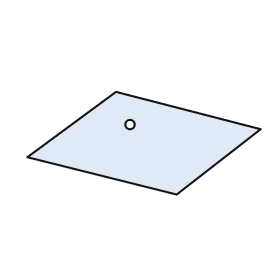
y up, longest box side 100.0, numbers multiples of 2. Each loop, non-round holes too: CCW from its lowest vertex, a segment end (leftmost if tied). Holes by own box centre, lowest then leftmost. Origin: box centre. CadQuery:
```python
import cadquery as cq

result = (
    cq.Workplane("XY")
    .moveTo(14.0, -22.0)
    .lineTo(50.0, 6.0)
    .lineTo(-12.0, 22.0)
    .lineTo(-50.0, -6.0)
    .close()
    .moveTo(-6.0, 8.0)
    .circle(2.0)
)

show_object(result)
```